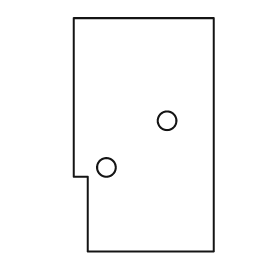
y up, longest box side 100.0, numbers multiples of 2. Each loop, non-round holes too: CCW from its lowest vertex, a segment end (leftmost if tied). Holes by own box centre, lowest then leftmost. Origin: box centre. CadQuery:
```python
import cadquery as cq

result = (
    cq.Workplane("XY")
    .moveTo(-24.0, -50.0)
    .lineTo(30.0, -50.0)
    .lineTo(30.0, 50.0)
    .lineTo(-30.0, 50.0)
    .lineTo(-30.0, -18.0)
    .lineTo(-24.0, -18.0)
    .close()
    .moveTo(-16.0, -14.0)
    .circle(4.0)
    .moveTo(10.0, 6.0)
    .circle(4.0)
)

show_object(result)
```